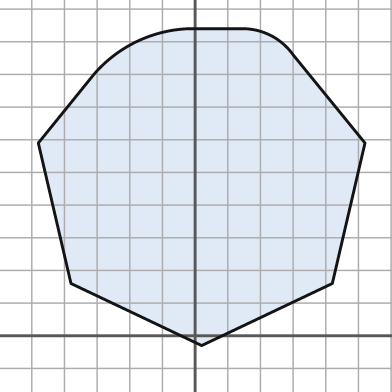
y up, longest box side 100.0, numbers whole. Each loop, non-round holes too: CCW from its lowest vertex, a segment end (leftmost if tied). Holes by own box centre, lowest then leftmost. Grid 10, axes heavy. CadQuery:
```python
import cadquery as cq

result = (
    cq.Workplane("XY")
    .moveTo(2.0, -3.0)
    .lineTo(42.0, 16.0)
    .lineTo(52.0, 59.0)
    .lineTo(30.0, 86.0)
    .threePointArc((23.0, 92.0), (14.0, 94.0))
    .lineTo(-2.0, 94.0)
    .threePointArc((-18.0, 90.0), (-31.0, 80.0))
    .lineTo(-48.0, 59.0)
    .lineTo(-38.0, 16.0)
    .close()
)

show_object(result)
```